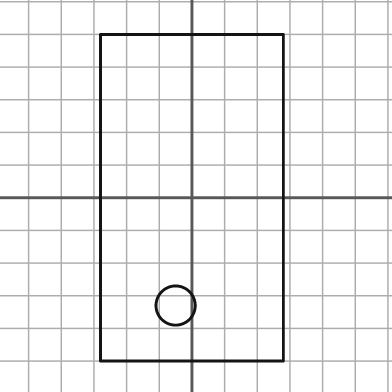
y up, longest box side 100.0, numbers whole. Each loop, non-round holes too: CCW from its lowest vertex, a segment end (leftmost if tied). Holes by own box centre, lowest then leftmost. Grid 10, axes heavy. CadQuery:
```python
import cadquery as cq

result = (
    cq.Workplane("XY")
    .moveTo(-28.0, -50.0)
    .lineTo(28.0, -50.0)
    .lineTo(28.0, 50.0)
    .lineTo(-28.0, 50.0)
    .close()
    .moveTo(-5.0, -33.0)
    .circle(6.0)
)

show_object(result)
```